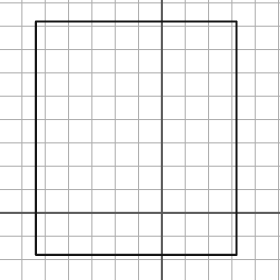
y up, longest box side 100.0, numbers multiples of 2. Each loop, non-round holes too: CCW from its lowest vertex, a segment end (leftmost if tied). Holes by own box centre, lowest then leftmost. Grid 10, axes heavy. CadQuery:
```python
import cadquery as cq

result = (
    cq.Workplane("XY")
    .moveTo(-54.0, -18.0)
    .lineTo(32.0, -18.0)
    .lineTo(32.0, 82.0)
    .lineTo(-54.0, 82.0)
    .close()
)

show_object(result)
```